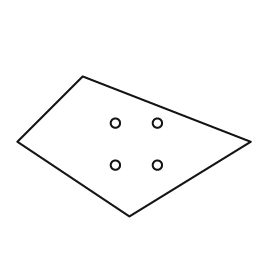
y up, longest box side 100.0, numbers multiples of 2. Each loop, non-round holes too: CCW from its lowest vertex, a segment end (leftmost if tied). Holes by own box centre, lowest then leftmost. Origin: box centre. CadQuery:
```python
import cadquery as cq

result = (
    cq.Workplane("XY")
    .moveTo(-2.0, -30.0)
    .lineTo(50.0, 2.0)
    .lineTo(-22.0, 30.0)
    .lineTo(-50.0, 2.0)
    .close()
    .moveTo(-8.0, -8.0)
    .circle(2.0)
    .moveTo(10.0, -8.0)
    .circle(2.0)
    .moveTo(-8.0, 10.0)
    .circle(2.0)
    .moveTo(10.0, 10.0)
    .circle(2.0)
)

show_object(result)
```